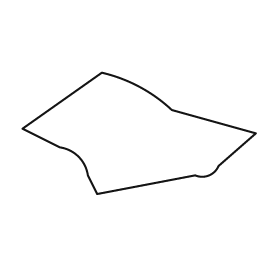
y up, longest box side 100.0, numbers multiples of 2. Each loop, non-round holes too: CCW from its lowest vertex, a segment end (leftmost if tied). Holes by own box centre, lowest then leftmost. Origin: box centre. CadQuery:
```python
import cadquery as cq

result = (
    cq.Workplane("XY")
    .moveTo(-18.0, -26.0)
    .lineTo(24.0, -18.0)
    .threePointArc((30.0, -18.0), (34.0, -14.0))
    .lineTo(50.0, 0.0)
    .lineTo(14.0, 10.0)
    .threePointArc((0.0, 20.0), (-16.0, 26.0))
    .lineTo(-50.0, 2.0)
    .lineTo(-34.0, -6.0)
    .threePointArc((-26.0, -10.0), (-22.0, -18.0))
    .close()
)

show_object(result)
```